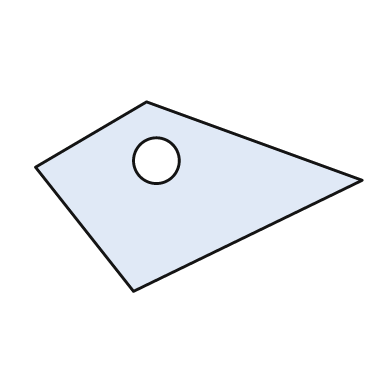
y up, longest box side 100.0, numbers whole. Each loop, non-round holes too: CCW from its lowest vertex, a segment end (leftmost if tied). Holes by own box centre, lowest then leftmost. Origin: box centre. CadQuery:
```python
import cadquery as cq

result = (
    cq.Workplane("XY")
    .moveTo(-20.0, -29.0)
    .lineTo(50.0, 5.0)
    .lineTo(-16.0, 29.0)
    .lineTo(-50.0, 9.0)
    .close()
    .moveTo(-13.0, 11.0)
    .circle(7.0)
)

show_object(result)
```